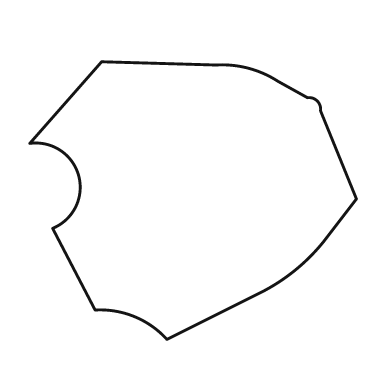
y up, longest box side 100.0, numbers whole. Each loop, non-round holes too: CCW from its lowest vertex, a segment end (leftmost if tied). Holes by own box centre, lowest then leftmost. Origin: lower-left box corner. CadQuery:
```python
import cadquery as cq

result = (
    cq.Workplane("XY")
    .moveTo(42.0, 0.0)
    .lineTo(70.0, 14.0)
    .threePointArc((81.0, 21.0), (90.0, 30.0))
    .lineTo(100.0, 43.0)
    .lineTo(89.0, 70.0)
    .threePointArc((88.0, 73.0), (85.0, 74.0))
    .lineTo(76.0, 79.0)
    .threePointArc((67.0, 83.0), (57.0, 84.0))
    .lineTo(22.0, 85.0)
    .lineTo(0.0, 60.0)
    .threePointArc((15.0, 50.0), (7.0, 34.0))
    .lineTo(20.0, 9.0)
    .threePointArc((32.0, 7.0), (42.0, 0.0))
    .close()
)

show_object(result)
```